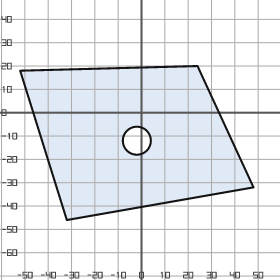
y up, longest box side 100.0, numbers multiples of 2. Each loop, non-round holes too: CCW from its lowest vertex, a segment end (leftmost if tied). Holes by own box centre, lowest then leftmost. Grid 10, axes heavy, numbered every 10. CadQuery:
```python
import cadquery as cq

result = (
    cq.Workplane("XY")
    .moveTo(-32.0, -46.0)
    .lineTo(48.0, -32.0)
    .lineTo(24.0, 20.0)
    .lineTo(-52.0, 18.0)
    .close()
    .moveTo(-2.0, -12.0)
    .circle(6.0)
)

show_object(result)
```